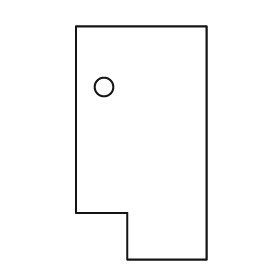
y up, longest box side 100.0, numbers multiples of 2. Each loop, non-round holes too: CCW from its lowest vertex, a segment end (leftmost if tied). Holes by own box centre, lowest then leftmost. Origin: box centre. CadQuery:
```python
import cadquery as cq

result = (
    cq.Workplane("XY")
    .moveTo(-6.0, -50.0)
    .lineTo(28.0, -50.0)
    .lineTo(28.0, 50.0)
    .lineTo(-28.0, 50.0)
    .lineTo(-28.0, -30.0)
    .lineTo(-6.0, -30.0)
    .close()
    .moveTo(-16.0, 24.0)
    .circle(4.0)
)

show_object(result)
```